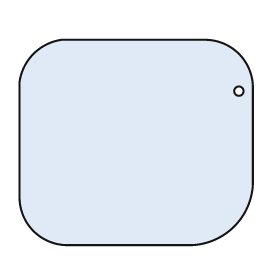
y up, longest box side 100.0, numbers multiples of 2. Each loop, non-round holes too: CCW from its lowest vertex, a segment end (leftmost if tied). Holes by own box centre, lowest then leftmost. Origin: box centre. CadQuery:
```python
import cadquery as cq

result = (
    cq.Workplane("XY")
    .moveTo(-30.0, -44.0)
    .lineTo(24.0, -44.0)
    .threePointArc((42.0, -36.0), (50.0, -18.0))
    .lineTo(50.0, 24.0)
    .threePointArc((44.0, 38.0), (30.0, 44.0))
    .lineTo(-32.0, 44.0)
    .threePointArc((-44.0, 38.0), (-50.0, 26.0))
    .lineTo(-50.0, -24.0)
    .threePointArc((-44.0, -38.0), (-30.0, -44.0))
    .close()
    .moveTo(44.0, 22.0)
    .circle(2.0)
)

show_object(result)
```